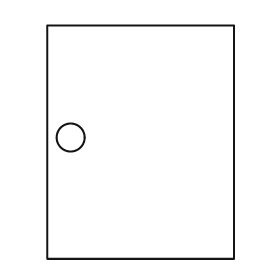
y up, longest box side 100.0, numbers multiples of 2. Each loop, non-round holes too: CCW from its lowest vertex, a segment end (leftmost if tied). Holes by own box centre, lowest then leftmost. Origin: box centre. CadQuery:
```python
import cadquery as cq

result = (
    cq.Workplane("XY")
    .moveTo(-40.0, -50.0)
    .lineTo(40.0, -50.0)
    .lineTo(40.0, 50.0)
    .lineTo(-40.0, 50.0)
    .close()
    .moveTo(-30.0, 2.0)
    .circle(6.0)
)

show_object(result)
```